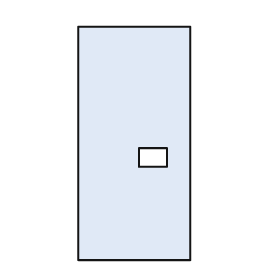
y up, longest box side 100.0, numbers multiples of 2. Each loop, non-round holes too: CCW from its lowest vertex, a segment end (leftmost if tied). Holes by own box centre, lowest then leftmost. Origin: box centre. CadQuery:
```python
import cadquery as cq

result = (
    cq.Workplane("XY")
    .moveTo(-24.0, -50.0)
    .lineTo(24.0, -50.0)
    .lineTo(24.0, 50.0)
    .lineTo(-24.0, 50.0)
    .close()
    .moveTo(2.0, -10.0)
    .lineTo(14.0, -10.0)
    .lineTo(14.0, -2.0)
    .lineTo(2.0, -2.0)
    .close()
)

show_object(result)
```